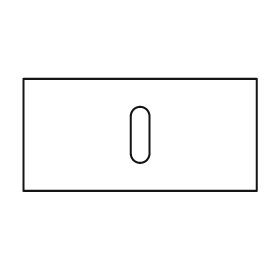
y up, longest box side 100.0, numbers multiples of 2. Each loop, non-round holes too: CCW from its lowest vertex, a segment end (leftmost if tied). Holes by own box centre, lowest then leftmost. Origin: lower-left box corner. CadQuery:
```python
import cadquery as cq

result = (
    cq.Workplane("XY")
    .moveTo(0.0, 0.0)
    .lineTo(100.0, 0.0)
    .lineTo(100.0, 48.0)
    .lineTo(0.0, 48.0)
    .close()
    .moveTo(46.0, 16.0)
    .threePointArc((50.0, 12.0), (54.0, 16.0))
    .lineTo(54.0, 32.0)
    .threePointArc((50.0, 36.0), (46.0, 32.0))
    .close()
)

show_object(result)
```